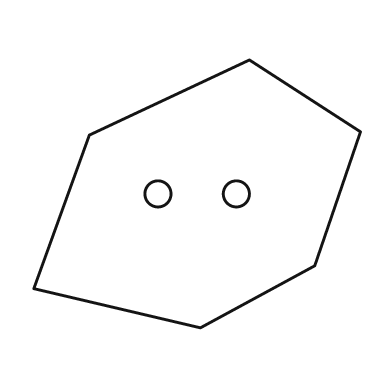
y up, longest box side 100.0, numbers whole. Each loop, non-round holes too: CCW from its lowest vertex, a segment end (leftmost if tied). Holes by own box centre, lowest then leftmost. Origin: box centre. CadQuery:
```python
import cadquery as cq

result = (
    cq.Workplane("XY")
    .moveTo(1.0, -41.0)
    .lineTo(36.0, -22.0)
    .lineTo(50.0, 19.0)
    .lineTo(16.0, 41.0)
    .lineTo(-33.0, 18.0)
    .lineTo(-50.0, -29.0)
    .close()
    .moveTo(-12.0, 0.0)
    .circle(4.0)
    .moveTo(12.0, 0.0)
    .circle(4.0)
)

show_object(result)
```